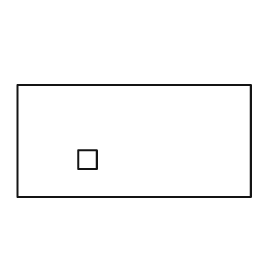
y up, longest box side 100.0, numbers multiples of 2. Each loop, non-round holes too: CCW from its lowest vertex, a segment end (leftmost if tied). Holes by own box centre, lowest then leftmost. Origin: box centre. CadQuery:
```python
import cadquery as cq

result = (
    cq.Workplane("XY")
    .moveTo(-50.0, -24.0)
    .lineTo(50.0, -24.0)
    .lineTo(50.0, 24.0)
    .lineTo(-50.0, 24.0)
    .close()
    .moveTo(-24.0, -12.0)
    .lineTo(-16.0, -12.0)
    .lineTo(-16.0, -4.0)
    .lineTo(-24.0, -4.0)
    .close()
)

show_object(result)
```